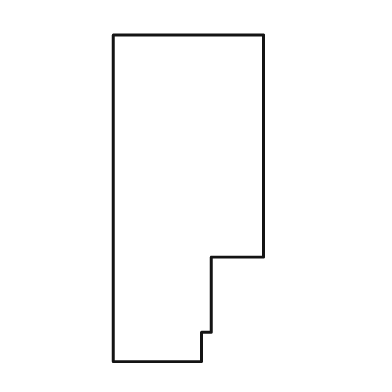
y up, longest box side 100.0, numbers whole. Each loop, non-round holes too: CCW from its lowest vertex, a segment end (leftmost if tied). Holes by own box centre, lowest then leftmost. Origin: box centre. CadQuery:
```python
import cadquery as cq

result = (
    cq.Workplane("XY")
    .moveTo(-23.0, -50.0)
    .lineTo(4.0, -50.0)
    .lineTo(4.0, -41.0)
    .lineTo(7.0, -41.0)
    .lineTo(7.0, -18.0)
    .lineTo(23.0, -18.0)
    .lineTo(23.0, 50.0)
    .lineTo(-23.0, 50.0)
    .close()
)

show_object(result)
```